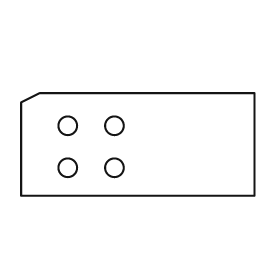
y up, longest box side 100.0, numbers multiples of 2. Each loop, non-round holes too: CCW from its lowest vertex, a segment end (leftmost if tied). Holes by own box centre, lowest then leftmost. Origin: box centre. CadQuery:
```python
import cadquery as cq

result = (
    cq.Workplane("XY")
    .moveTo(-50.0, -22.0)
    .lineTo(50.0, -22.0)
    .lineTo(50.0, 22.0)
    .lineTo(-42.0, 22.0)
    .lineTo(-50.0, 18.0)
    .close()
    .moveTo(-30.0, -10.0)
    .circle(4.0)
    .moveTo(-10.0, -10.0)
    .circle(4.0)
    .moveTo(-30.0, 8.0)
    .circle(4.0)
    .moveTo(-10.0, 8.0)
    .circle(4.0)
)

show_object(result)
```